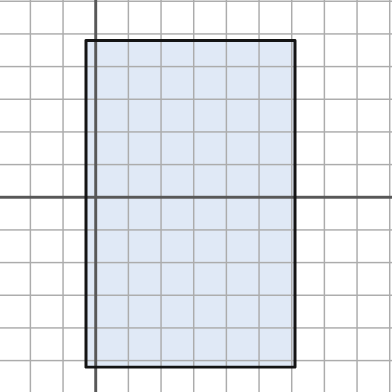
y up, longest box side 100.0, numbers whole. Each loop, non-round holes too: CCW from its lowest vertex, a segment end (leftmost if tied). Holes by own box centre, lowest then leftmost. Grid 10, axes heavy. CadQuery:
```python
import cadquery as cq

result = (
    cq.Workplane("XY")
    .moveTo(-3.0, -52.0)
    .lineTo(61.0, -52.0)
    .lineTo(61.0, 48.0)
    .lineTo(-3.0, 48.0)
    .close()
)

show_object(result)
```